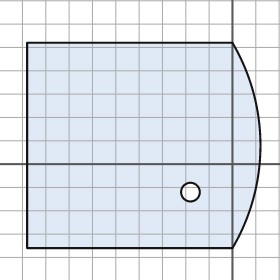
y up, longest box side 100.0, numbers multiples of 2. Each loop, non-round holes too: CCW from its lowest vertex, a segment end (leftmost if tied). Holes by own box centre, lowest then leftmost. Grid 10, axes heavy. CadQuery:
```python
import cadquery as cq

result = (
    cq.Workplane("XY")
    .moveTo(-88.0, -36.0)
    .lineTo(0.0, -36.0)
    .threePointArc((12.0, 8.0), (0.0, 52.0))
    .lineTo(-88.0, 52.0)
    .close()
    .moveTo(-18.0, -12.0)
    .circle(4.0)
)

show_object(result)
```